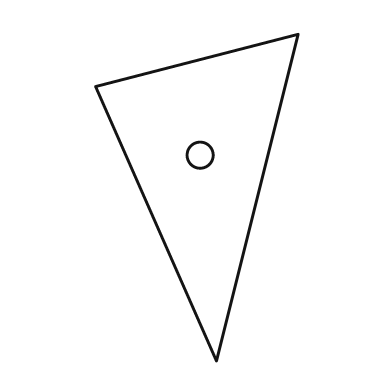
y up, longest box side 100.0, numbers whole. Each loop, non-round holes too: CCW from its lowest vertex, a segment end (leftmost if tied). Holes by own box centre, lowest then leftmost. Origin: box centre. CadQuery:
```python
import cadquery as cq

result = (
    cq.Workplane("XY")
    .moveTo(6.0, -50.0)
    .lineTo(31.0, 50.0)
    .lineTo(-31.0, 34.0)
    .close()
    .moveTo(1.0, 13.0)
    .circle(4.0)
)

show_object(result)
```